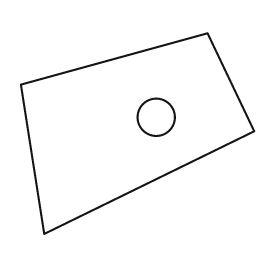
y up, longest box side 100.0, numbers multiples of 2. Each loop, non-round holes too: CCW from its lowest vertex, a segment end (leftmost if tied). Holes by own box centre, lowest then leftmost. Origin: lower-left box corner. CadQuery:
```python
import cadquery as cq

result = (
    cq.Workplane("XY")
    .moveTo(10.0, 0.0)
    .lineTo(100.0, 44.0)
    .lineTo(80.0, 86.0)
    .lineTo(0.0, 64.0)
    .close()
    .moveTo(58.0, 50.0)
    .circle(8.0)
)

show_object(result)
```